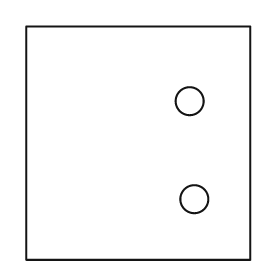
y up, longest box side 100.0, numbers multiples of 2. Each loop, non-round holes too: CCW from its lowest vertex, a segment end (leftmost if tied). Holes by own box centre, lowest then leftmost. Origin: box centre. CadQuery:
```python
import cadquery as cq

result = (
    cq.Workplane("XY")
    .moveTo(-48.0, -50.0)
    .lineTo(48.0, -50.0)
    .lineTo(48.0, 50.0)
    .lineTo(-48.0, 50.0)
    .close()
    .moveTo(24.0, -24.0)
    .circle(6.0)
    .moveTo(22.0, 18.0)
    .circle(6.0)
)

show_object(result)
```